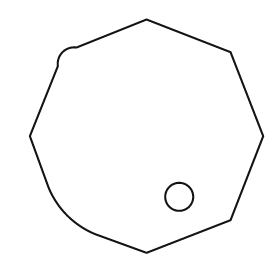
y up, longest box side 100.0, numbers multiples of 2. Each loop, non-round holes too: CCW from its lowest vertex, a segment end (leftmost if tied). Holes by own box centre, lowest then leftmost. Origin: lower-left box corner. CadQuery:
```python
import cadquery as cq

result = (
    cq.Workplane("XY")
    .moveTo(50.0, 0.0)
    .lineTo(86.0, 14.0)
    .lineTo(100.0, 50.0)
    .lineTo(86.0, 86.0)
    .lineTo(50.0, 100.0)
    .lineTo(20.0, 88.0)
    .threePointArc((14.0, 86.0), (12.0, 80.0))
    .lineTo(0.0, 50.0)
    .lineTo(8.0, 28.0)
    .threePointArc((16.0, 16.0), (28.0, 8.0))
    .close()
    .moveTo(64.0, 24.0)
    .circle(6.0)
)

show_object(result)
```